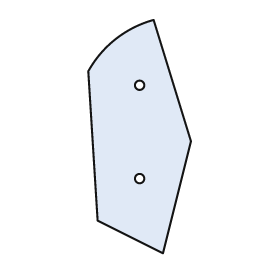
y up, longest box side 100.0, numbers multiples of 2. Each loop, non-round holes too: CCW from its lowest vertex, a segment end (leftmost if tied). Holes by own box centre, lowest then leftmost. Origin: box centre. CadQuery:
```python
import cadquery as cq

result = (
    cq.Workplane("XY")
    .moveTo(10.0, -50.0)
    .lineTo(22.0, -2.0)
    .lineTo(6.0, 50.0)
    .threePointArc((-10.0, 42.0), (-22.0, 28.0))
    .lineTo(-18.0, -36.0)
    .close()
    .moveTo(0.0, -18.0)
    .circle(2.0)
    .moveTo(0.0, 22.0)
    .circle(2.0)
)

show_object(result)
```